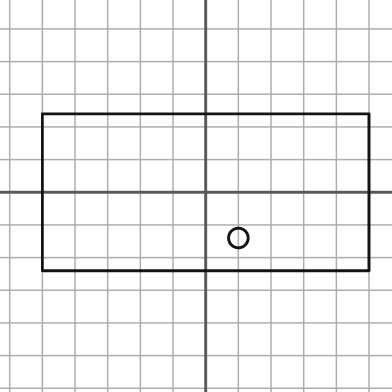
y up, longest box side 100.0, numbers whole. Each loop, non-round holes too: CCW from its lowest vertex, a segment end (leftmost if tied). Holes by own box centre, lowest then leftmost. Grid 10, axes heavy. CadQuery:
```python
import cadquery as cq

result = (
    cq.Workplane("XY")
    .moveTo(-50.0, -24.0)
    .lineTo(50.0, -24.0)
    .lineTo(50.0, 24.0)
    .lineTo(-50.0, 24.0)
    .close()
    .moveTo(10.0, -14.0)
    .circle(3.0)
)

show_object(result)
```